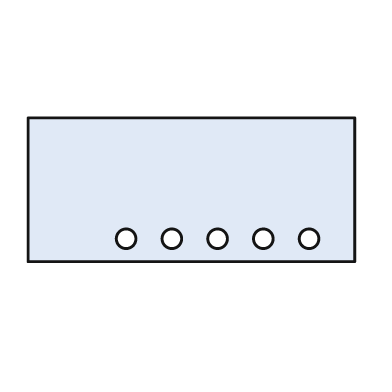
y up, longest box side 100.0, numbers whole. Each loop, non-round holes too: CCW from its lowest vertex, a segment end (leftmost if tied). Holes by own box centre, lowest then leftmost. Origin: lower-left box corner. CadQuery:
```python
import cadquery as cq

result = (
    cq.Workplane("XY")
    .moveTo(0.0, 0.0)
    .lineTo(100.0, 0.0)
    .lineTo(100.0, 44.0)
    .lineTo(0.0, 44.0)
    .close()
    .moveTo(30.0, 7.0)
    .circle(3.0)
    .moveTo(44.0, 7.0)
    .circle(3.0)
    .moveTo(58.0, 7.0)
    .circle(3.0)
    .moveTo(72.0, 7.0)
    .circle(3.0)
    .moveTo(86.0, 7.0)
    .circle(3.0)
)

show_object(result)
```